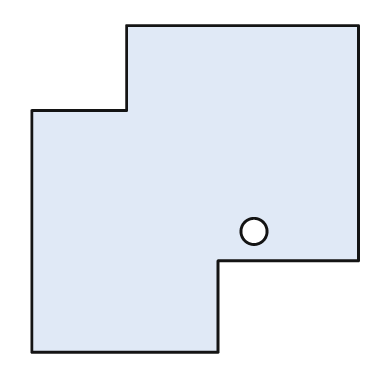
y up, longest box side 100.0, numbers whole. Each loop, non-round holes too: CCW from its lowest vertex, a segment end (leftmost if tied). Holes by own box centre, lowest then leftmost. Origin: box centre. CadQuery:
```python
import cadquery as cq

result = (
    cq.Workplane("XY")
    .moveTo(-50.0, -50.0)
    .lineTo(7.0, -50.0)
    .lineTo(7.0, -22.0)
    .lineTo(50.0, -22.0)
    .lineTo(50.0, 50.0)
    .lineTo(-21.0, 50.0)
    .lineTo(-21.0, 24.0)
    .lineTo(-50.0, 24.0)
    .close()
    .moveTo(18.0, -13.0)
    .circle(4.0)
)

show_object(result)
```